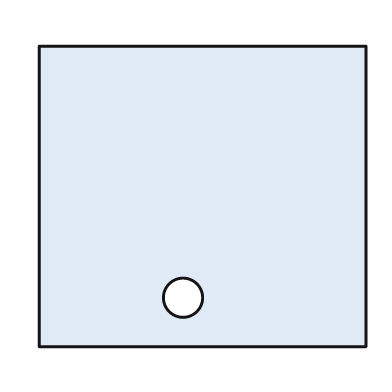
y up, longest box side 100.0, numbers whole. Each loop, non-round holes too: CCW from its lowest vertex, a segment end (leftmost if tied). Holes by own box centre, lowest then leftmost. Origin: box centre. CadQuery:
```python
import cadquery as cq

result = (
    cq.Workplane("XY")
    .moveTo(-50.0, -46.0)
    .lineTo(50.0, -46.0)
    .lineTo(50.0, 46.0)
    .lineTo(-50.0, 46.0)
    .close()
    .moveTo(-6.0, -31.0)
    .circle(6.0)
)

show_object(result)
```